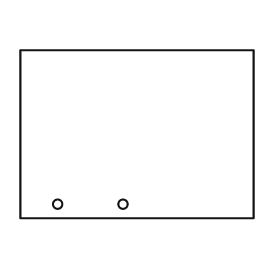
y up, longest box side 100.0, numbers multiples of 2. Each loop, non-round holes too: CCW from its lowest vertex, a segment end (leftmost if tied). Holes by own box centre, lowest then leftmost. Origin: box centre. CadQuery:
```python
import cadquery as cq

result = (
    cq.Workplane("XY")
    .moveTo(-50.0, -36.0)
    .lineTo(50.0, -36.0)
    .lineTo(50.0, 36.0)
    .lineTo(-50.0, 36.0)
    .close()
    .moveTo(-34.0, -30.0)
    .circle(2.0)
    .moveTo(-6.0, -30.0)
    .circle(2.0)
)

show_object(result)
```